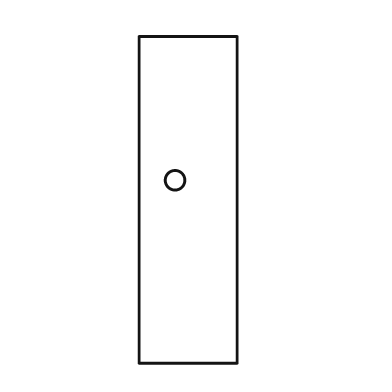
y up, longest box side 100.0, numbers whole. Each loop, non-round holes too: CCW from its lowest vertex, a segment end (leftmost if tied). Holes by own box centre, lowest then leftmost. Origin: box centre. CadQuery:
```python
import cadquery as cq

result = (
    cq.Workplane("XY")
    .moveTo(-15.0, -50.0)
    .lineTo(15.0, -50.0)
    .lineTo(15.0, 50.0)
    .lineTo(-15.0, 50.0)
    .close()
    .moveTo(-4.0, 6.0)
    .circle(3.0)
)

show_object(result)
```